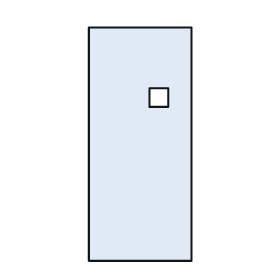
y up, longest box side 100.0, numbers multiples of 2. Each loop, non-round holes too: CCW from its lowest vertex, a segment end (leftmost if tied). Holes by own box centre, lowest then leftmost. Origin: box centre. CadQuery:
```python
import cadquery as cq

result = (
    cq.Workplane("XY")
    .moveTo(-22.0, -50.0)
    .lineTo(22.0, -50.0)
    .lineTo(22.0, 50.0)
    .lineTo(-22.0, 50.0)
    .close()
    .moveTo(4.0, 16.0)
    .lineTo(12.0, 16.0)
    .lineTo(12.0, 24.0)
    .lineTo(4.0, 24.0)
    .close()
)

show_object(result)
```